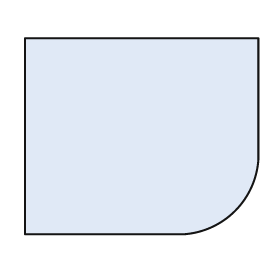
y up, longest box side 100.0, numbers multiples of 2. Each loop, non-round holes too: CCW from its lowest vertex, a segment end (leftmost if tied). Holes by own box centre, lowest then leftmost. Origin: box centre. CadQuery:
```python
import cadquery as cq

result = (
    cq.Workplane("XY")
    .moveTo(-50.0, -42.0)
    .lineTo(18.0, -42.0)
    .threePointArc((40.0, -32.0), (50.0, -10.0))
    .lineTo(50.0, 42.0)
    .lineTo(-50.0, 42.0)
    .close()
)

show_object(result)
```